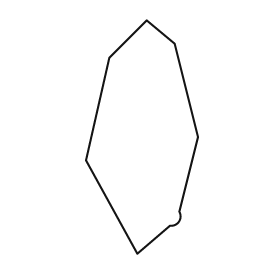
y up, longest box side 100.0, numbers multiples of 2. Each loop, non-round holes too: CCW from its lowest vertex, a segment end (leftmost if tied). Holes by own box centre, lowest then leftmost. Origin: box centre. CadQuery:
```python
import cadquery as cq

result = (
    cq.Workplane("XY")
    .moveTo(-2.0, -50.0)
    .lineTo(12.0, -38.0)
    .threePointArc((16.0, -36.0), (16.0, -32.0))
    .lineTo(24.0, 0.0)
    .lineTo(14.0, 40.0)
    .lineTo(2.0, 50.0)
    .lineTo(-14.0, 34.0)
    .lineTo(-24.0, -10.0)
    .close()
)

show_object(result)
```